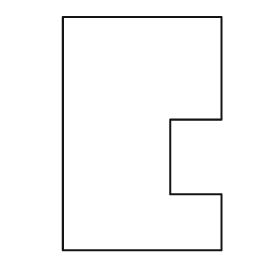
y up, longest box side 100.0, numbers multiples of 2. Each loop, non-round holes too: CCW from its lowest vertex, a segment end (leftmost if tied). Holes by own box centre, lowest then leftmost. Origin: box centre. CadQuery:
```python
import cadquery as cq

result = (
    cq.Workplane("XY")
    .moveTo(-34.0, -50.0)
    .lineTo(34.0, -50.0)
    .lineTo(34.0, -26.0)
    .lineTo(12.0, -26.0)
    .lineTo(12.0, 6.0)
    .lineTo(34.0, 6.0)
    .lineTo(34.0, 50.0)
    .lineTo(-34.0, 50.0)
    .close()
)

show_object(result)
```